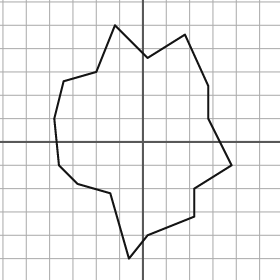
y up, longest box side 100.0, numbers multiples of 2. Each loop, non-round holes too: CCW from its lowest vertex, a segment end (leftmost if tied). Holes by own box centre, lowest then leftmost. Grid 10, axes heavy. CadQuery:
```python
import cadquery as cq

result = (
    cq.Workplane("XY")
    .moveTo(-6.0, -50.0)
    .lineTo(2.0, -40.0)
    .lineTo(22.0, -32.0)
    .lineTo(22.0, -20.0)
    .lineTo(38.0, -10.0)
    .lineTo(28.0, 10.0)
    .lineTo(28.0, 24.0)
    .lineTo(18.0, 46.0)
    .lineTo(2.0, 36.0)
    .lineTo(-12.0, 50.0)
    .lineTo(-20.0, 30.0)
    .lineTo(-34.0, 26.0)
    .lineTo(-38.0, 10.0)
    .lineTo(-36.0, -10.0)
    .lineTo(-28.0, -18.0)
    .lineTo(-14.0, -22.0)
    .close()
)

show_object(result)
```